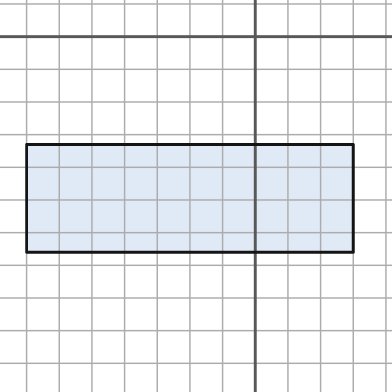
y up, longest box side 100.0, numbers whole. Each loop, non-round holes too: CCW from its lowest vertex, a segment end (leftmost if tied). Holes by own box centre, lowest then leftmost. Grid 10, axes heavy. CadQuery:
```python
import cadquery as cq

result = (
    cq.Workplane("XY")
    .moveTo(-70.0, -66.0)
    .lineTo(30.0, -66.0)
    .lineTo(30.0, -33.0)
    .lineTo(-70.0, -33.0)
    .close()
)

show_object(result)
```